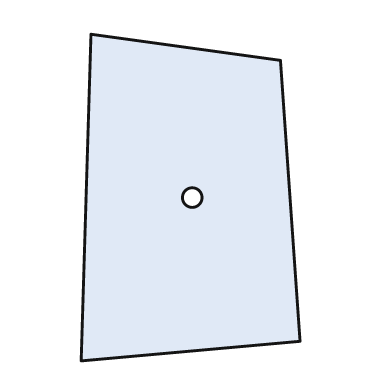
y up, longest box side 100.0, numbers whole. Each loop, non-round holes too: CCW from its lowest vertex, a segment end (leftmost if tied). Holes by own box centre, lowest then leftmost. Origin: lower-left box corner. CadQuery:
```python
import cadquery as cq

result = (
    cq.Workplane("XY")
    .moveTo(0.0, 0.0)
    .lineTo(67.0, 6.0)
    .lineTo(61.0, 92.0)
    .lineTo(3.0, 100.0)
    .close()
    .moveTo(34.0, 50.0)
    .circle(3.0)
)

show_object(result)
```